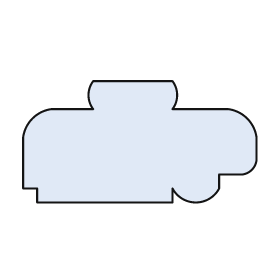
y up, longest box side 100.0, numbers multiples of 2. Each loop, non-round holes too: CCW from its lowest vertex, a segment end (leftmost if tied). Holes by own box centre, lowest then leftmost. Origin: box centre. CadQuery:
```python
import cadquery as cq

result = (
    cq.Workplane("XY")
    .moveTo(-44.0, -26.0)
    .lineTo(14.0, -26.0)
    .lineTo(14.0, -20.0)
    .threePointArc((24.0, -26.0), (34.0, -20.0))
    .lineTo(34.0, -14.0)
    .lineTo(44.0, -14.0)
    .threePointArc((48.0, -12.0), (50.0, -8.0))
    .lineTo(50.0, 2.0)
    .threePointArc((46.0, 10.0), (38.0, 14.0))
    .lineTo(14.0, 14.0)
    .threePointArc((16.0, 20.0), (14.0, 26.0))
    .lineTo(-20.0, 26.0)
    .threePointArc((-22.0, 20.0), (-20.0, 14.0))
    .lineTo(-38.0, 14.0)
    .threePointArc((-46.0, 10.0), (-50.0, 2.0))
    .lineTo(-50.0, -20.0)
    .lineTo(-44.0, -20.0)
    .close()
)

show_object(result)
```